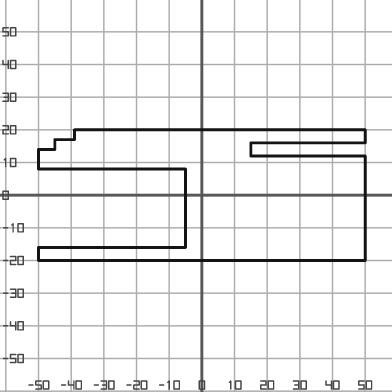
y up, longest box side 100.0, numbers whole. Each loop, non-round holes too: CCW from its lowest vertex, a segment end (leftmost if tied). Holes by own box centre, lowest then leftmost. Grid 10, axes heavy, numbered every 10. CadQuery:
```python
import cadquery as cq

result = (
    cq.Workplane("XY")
    .moveTo(-50.0, -20.0)
    .lineTo(50.0, -20.0)
    .lineTo(50.0, 12.0)
    .lineTo(15.0, 12.0)
    .lineTo(15.0, 16.0)
    .lineTo(50.0, 16.0)
    .lineTo(50.0, 20.0)
    .lineTo(-39.0, 20.0)
    .lineTo(-39.0, 17.0)
    .lineTo(-45.0, 17.0)
    .lineTo(-45.0, 14.0)
    .lineTo(-50.0, 14.0)
    .lineTo(-50.0, 8.0)
    .lineTo(-5.0, 8.0)
    .lineTo(-5.0, -16.0)
    .lineTo(-50.0, -16.0)
    .close()
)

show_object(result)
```